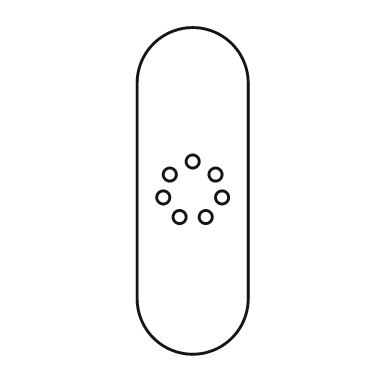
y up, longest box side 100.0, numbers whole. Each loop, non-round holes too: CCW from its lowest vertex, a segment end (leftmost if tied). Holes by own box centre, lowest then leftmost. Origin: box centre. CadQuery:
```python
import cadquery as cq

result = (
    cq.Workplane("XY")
    .moveTo(-17.0, -33.0)
    .threePointArc((0.0, -50.0), (17.0, -33.0))
    .lineTo(17.0, 33.0)
    .threePointArc((0.0, 50.0), (-17.0, 33.0))
    .close()
    .moveTo(-4.0, -8.0)
    .circle(2.0)
    .moveTo(4.0, -8.0)
    .circle(2.0)
    .moveTo(-9.0, -2.0)
    .circle(2.0)
    .moveTo(9.0, -2.0)
    .circle(2.0)
    .moveTo(-7.0, 5.0)
    .circle(2.0)
    .moveTo(7.0, 5.0)
    .circle(2.0)
    .moveTo(0.0, 9.0)
    .circle(2.0)
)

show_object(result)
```